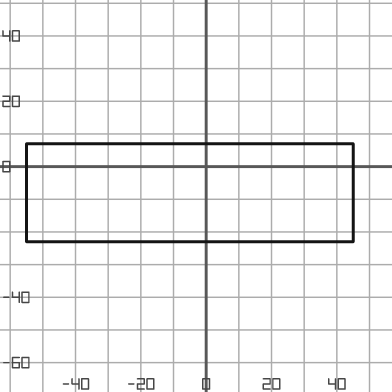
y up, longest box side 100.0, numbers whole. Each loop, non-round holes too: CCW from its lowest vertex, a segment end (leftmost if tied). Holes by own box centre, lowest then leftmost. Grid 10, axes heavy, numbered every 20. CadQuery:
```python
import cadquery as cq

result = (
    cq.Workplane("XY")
    .moveTo(-55.0, -23.0)
    .lineTo(45.0, -23.0)
    .lineTo(45.0, 7.0)
    .lineTo(-55.0, 7.0)
    .close()
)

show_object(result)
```